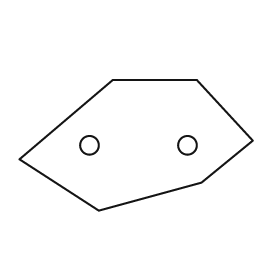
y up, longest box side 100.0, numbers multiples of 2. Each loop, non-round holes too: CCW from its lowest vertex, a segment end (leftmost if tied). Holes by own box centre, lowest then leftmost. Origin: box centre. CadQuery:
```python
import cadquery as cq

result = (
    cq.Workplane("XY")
    .moveTo(-16.0, -28.0)
    .lineTo(28.0, -16.0)
    .lineTo(50.0, 2.0)
    .lineTo(26.0, 28.0)
    .lineTo(-10.0, 28.0)
    .lineTo(-50.0, -6.0)
    .close()
    .moveTo(-20.0, 0.0)
    .circle(4.0)
    .moveTo(22.0, 0.0)
    .circle(4.0)
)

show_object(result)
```